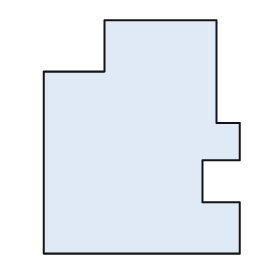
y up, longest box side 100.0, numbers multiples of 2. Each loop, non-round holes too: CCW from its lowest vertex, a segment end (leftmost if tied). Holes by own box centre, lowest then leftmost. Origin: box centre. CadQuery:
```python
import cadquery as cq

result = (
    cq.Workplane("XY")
    .moveTo(-42.0, -50.0)
    .lineTo(42.0, -50.0)
    .lineTo(42.0, -28.0)
    .lineTo(26.0, -28.0)
    .lineTo(26.0, -10.0)
    .lineTo(42.0, -10.0)
    .lineTo(42.0, 6.0)
    .lineTo(32.0, 6.0)
    .lineTo(32.0, 50.0)
    .lineTo(-16.0, 50.0)
    .lineTo(-16.0, 28.0)
    .lineTo(-42.0, 28.0)
    .close()
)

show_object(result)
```